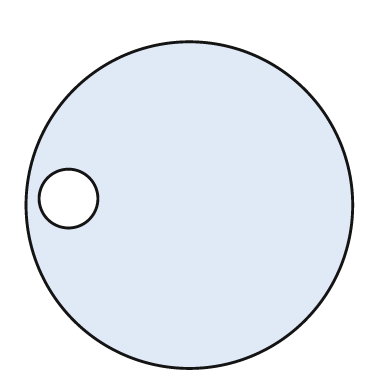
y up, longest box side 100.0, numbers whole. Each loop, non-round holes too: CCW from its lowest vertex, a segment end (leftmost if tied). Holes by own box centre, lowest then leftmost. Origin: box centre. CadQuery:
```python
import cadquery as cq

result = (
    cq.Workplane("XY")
    .moveTo(0.0, 0.0)
    .circle(50.0)
    .moveTo(-37.0, 2.0)
    .circle(9.0)
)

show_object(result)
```